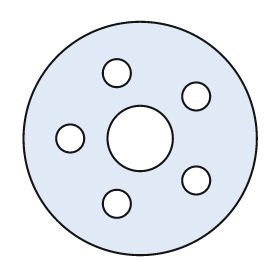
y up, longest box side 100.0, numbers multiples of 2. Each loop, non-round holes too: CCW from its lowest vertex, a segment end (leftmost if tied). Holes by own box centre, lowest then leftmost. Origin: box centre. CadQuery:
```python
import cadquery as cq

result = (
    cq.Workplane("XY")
    .moveTo(0.0, 0.0)
    .circle(50.0)
    .moveTo(-10.0, -28.0)
    .circle(6.0)
    .moveTo(24.0, -18.0)
    .circle(6.0)
    .moveTo(-30.0, 0.0)
    .circle(6.0)
    .moveTo(0.0, 0.0)
    .circle(14.0)
    .moveTo(24.0, 18.0)
    .circle(6.0)
    .moveTo(-10.0, 28.0)
    .circle(6.0)
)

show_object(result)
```